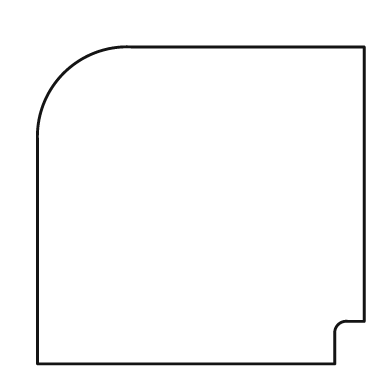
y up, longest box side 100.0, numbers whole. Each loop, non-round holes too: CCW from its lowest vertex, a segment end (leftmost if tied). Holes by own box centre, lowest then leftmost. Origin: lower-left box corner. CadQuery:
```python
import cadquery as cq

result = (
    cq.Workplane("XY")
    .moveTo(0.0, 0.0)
    .lineTo(91.0, 0.0)
    .lineTo(91.0, 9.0)
    .threePointArc((92.0, 12.0), (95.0, 13.0))
    .lineTo(100.0, 13.0)
    .lineTo(100.0, 97.0)
    .lineTo(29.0, 97.0)
    .threePointArc((8.0, 89.0), (0.0, 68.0))
    .close()
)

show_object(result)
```